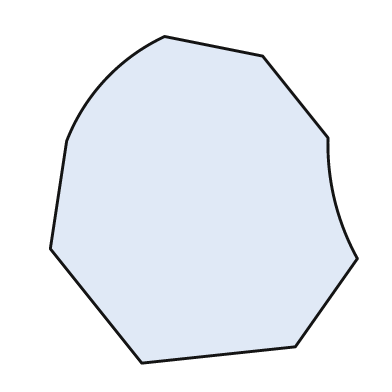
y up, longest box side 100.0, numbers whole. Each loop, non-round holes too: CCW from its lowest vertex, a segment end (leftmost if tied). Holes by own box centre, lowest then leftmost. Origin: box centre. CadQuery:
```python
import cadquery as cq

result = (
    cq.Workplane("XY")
    .moveTo(-19.0, -50.0)
    .lineTo(28.0, -45.0)
    .lineTo(47.0, -18.0)
    .threePointArc((40.0, 0.0), (38.0, 19.0))
    .lineTo(18.0, 44.0)
    .lineTo(-12.0, 50.0)
    .threePointArc((-30.0, 37.0), (-42.0, 18.0))
    .lineTo(-47.0, -15.0)
    .close()
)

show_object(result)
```